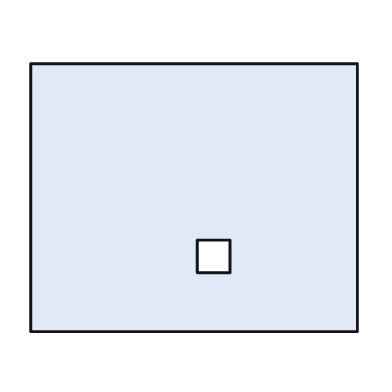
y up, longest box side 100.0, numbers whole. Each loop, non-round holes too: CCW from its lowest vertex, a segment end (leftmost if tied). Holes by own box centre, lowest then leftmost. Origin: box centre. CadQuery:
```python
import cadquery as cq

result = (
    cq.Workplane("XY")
    .moveTo(-50.0, -41.0)
    .lineTo(50.0, -41.0)
    .lineTo(50.0, 41.0)
    .lineTo(-50.0, 41.0)
    .close()
    .moveTo(1.0, -23.0)
    .lineTo(11.0, -23.0)
    .lineTo(11.0, -13.0)
    .lineTo(1.0, -13.0)
    .close()
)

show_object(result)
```